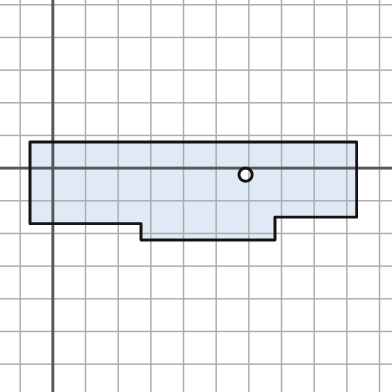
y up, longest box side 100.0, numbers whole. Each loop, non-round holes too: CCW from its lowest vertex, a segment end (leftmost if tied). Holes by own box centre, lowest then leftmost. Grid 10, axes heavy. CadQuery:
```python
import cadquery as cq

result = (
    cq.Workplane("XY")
    .moveTo(27.0, -22.0)
    .lineTo(68.0, -22.0)
    .lineTo(68.0, -15.0)
    .lineTo(93.0, -15.0)
    .lineTo(93.0, 8.0)
    .lineTo(-7.0, 8.0)
    .lineTo(-7.0, -17.0)
    .lineTo(27.0, -17.0)
    .close()
    .moveTo(59.0, -2.0)
    .circle(2.0)
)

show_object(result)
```